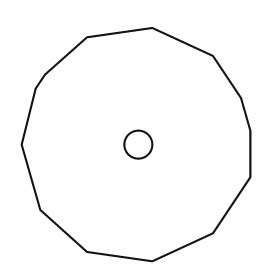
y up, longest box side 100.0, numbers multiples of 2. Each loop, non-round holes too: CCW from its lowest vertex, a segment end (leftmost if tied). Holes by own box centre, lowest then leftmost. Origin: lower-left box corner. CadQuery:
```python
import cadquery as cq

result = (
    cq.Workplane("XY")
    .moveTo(56.0, 0.0)
    .lineTo(82.0, 12.0)
    .lineTo(98.0, 36.0)
    .lineTo(98.0, 56.0)
    .lineTo(94.0, 70.0)
    .lineTo(82.0, 88.0)
    .lineTo(56.0, 100.0)
    .lineTo(28.0, 96.0)
    .lineTo(10.0, 80.0)
    .lineTo(6.0, 74.0)
    .lineTo(0.0, 50.0)
    .lineTo(8.0, 22.0)
    .lineTo(28.0, 4.0)
    .close()
    .moveTo(50.0, 50.0)
    .circle(6.0)
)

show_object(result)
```